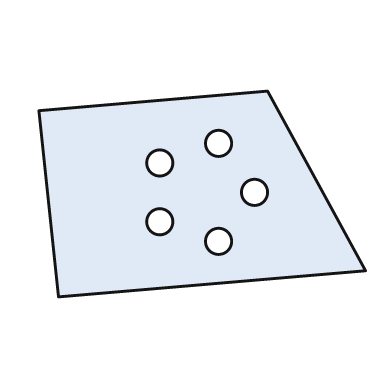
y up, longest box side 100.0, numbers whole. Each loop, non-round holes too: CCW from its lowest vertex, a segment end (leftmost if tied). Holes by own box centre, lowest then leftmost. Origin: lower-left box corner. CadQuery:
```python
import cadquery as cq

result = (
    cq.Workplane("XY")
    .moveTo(6.0, 0.0)
    .lineTo(100.0, 8.0)
    .lineTo(70.0, 63.0)
    .lineTo(0.0, 57.0)
    .close()
    .moveTo(55.0, 17.0)
    .circle(4.0)
    .moveTo(37.0, 23.0)
    .circle(4.0)
    .moveTo(66.0, 32.0)
    .circle(4.0)
    .moveTo(37.0, 41.0)
    .circle(4.0)
    .moveTo(55.0, 47.0)
    .circle(4.0)
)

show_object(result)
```